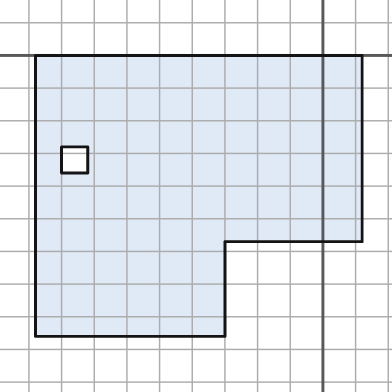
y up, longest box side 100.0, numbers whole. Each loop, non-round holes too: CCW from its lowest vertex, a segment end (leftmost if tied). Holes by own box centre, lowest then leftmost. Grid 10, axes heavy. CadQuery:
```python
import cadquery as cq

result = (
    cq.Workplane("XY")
    .moveTo(-88.0, -86.0)
    .lineTo(-30.0, -86.0)
    .lineTo(-30.0, -57.0)
    .lineTo(12.0, -57.0)
    .lineTo(12.0, 0.0)
    .lineTo(-88.0, 0.0)
    .close()
    .moveTo(-80.0, -36.0)
    .lineTo(-72.0, -36.0)
    .lineTo(-72.0, -28.0)
    .lineTo(-80.0, -28.0)
    .close()
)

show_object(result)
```